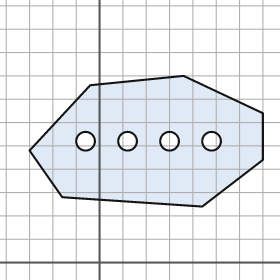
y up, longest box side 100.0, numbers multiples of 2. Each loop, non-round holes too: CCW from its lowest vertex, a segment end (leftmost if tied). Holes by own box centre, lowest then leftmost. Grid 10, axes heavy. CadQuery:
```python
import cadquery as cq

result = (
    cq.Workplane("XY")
    .moveTo(44.0, 24.0)
    .lineTo(70.0, 44.0)
    .lineTo(70.0, 64.0)
    .lineTo(36.0, 80.0)
    .lineTo(-4.0, 76.0)
    .lineTo(-30.0, 48.0)
    .lineTo(-16.0, 28.0)
    .close()
    .moveTo(-6.0, 52.0)
    .circle(4.0)
    .moveTo(12.0, 52.0)
    .circle(4.0)
    .moveTo(30.0, 52.0)
    .circle(4.0)
    .moveTo(48.0, 52.0)
    .circle(4.0)
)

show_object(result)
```